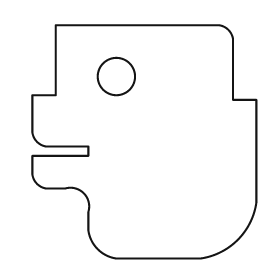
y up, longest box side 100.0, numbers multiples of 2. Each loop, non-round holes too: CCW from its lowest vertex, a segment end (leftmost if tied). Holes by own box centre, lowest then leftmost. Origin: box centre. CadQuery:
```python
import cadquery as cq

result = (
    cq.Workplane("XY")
    .moveTo(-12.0, -50.0)
    .lineTo(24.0, -50.0)
    .threePointArc((40.0, -42.0), (48.0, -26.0))
    .lineTo(48.0, 18.0)
    .lineTo(38.0, 18.0)
    .lineTo(38.0, 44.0)
    .threePointArc((36.0, 48.0), (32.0, 50.0))
    .lineTo(-38.0, 50.0)
    .lineTo(-38.0, 20.0)
    .lineTo(-48.0, 20.0)
    .lineTo(-48.0, 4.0)
    .threePointArc((-46.0, 0.0), (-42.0, -2.0))
    .lineTo(-24.0, -2.0)
    .lineTo(-24.0, -6.0)
    .lineTo(-48.0, -6.0)
    .lineTo(-48.0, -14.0)
    .threePointArc((-46.0, -18.0), (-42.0, -20.0))
    .lineTo(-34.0, -20.0)
    .threePointArc((-26.0, -22.0), (-24.0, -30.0))
    .lineTo(-24.0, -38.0)
    .threePointArc((-20.0, -46.0), (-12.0, -50.0))
    .close()
    .moveTo(-12.0, 28.0)
    .circle(8.0)
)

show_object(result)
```